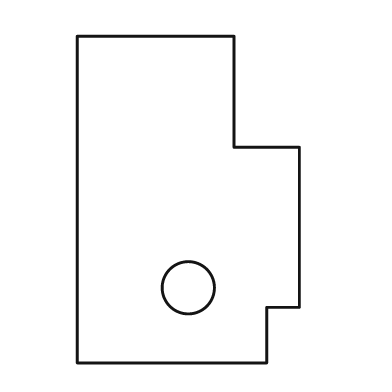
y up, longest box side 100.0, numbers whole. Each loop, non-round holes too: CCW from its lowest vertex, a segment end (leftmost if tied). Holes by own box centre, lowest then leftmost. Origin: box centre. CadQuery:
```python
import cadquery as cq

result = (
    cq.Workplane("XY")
    .moveTo(-34.0, -50.0)
    .lineTo(24.0, -50.0)
    .lineTo(24.0, -33.0)
    .lineTo(34.0, -33.0)
    .lineTo(34.0, 16.0)
    .lineTo(14.0, 16.0)
    .lineTo(14.0, 50.0)
    .lineTo(-34.0, 50.0)
    .close()
    .moveTo(0.0, -27.0)
    .circle(8.0)
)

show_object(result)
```